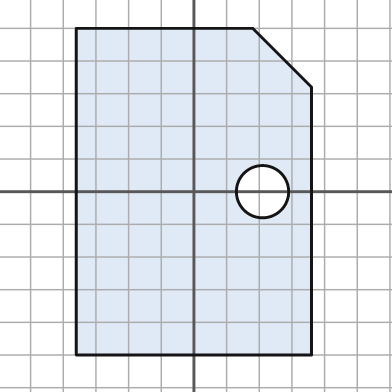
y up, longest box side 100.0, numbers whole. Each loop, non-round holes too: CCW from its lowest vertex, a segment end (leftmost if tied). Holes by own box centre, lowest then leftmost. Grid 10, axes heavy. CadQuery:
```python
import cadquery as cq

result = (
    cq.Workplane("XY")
    .moveTo(-36.0, -50.0)
    .lineTo(36.0, -50.0)
    .lineTo(36.0, 32.0)
    .lineTo(18.0, 50.0)
    .lineTo(-36.0, 50.0)
    .close()
    .moveTo(21.0, 0.0)
    .circle(8.0)
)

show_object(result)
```